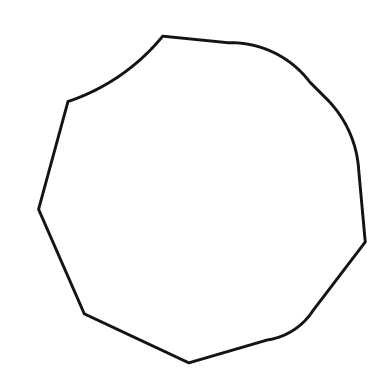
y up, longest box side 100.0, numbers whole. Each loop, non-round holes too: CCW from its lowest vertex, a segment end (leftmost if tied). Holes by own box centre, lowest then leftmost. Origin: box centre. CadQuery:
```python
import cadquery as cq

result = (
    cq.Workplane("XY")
    .moveTo(-4.0, -50.0)
    .lineTo(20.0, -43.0)
    .threePointArc((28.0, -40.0), (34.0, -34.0))
    .lineTo(50.0, -13.0)
    .lineTo(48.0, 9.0)
    .threePointArc((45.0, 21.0), (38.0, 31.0))
    .lineTo(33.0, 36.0)
    .threePointArc((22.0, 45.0), (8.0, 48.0))
    .lineTo(-12.0, 50.0)
    .threePointArc((-25.0, 38.0), (-41.0, 30.0))
    .lineTo(-50.0, -3.0)
    .lineTo(-36.0, -35.0)
    .close()
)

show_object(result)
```